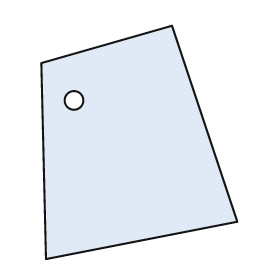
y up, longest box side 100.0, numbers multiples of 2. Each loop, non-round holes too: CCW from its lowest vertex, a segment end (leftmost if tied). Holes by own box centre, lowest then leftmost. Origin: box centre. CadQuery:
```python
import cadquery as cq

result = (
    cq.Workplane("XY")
    .moveTo(-40.0, -50.0)
    .lineTo(42.0, -34.0)
    .lineTo(14.0, 50.0)
    .lineTo(-42.0, 34.0)
    .close()
    .moveTo(-28.0, 18.0)
    .circle(4.0)
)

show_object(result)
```